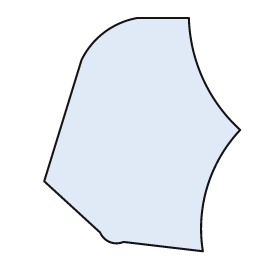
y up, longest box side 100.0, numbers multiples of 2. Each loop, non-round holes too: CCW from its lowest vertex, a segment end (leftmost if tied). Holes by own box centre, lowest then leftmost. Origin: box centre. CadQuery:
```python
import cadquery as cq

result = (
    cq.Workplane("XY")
    .moveTo(26.0, -50.0)
    .threePointArc((28.0, -22.0), (42.0, 2.0))
    .threePointArc((26.0, 24.0), (20.0, 50.0))
    .lineTo(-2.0, 50.0)
    .threePointArc((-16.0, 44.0), (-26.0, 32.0))
    .lineTo(-42.0, -20.0)
    .lineTo(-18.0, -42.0)
    .threePointArc((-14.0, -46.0), (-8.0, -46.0))
    .close()
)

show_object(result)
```